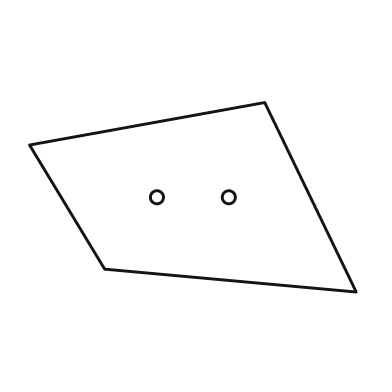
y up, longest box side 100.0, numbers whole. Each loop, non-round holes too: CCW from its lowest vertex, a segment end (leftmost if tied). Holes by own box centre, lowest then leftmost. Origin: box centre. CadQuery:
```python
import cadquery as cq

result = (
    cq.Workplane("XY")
    .moveTo(50.0, -29.0)
    .lineTo(22.0, 29.0)
    .lineTo(-50.0, 16.0)
    .lineTo(-27.0, -22.0)
    .close()
    .moveTo(-11.0, 0.0)
    .circle(2.0)
    .moveTo(11.0, 0.0)
    .circle(2.0)
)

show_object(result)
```